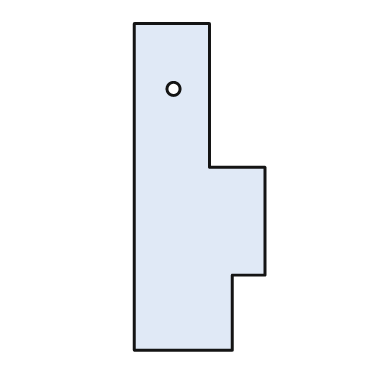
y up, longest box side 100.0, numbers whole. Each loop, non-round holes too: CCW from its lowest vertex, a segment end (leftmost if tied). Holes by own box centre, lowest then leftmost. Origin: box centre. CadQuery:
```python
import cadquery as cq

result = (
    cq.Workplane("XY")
    .moveTo(-20.0, -50.0)
    .lineTo(10.0, -50.0)
    .lineTo(10.0, -27.0)
    .lineTo(20.0, -27.0)
    .lineTo(20.0, 6.0)
    .lineTo(3.0, 6.0)
    .lineTo(3.0, 50.0)
    .lineTo(-20.0, 50.0)
    .close()
    .moveTo(-8.0, 30.0)
    .circle(2.0)
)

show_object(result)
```